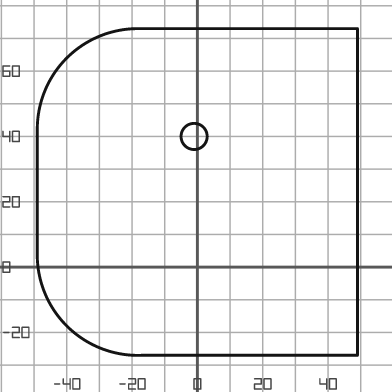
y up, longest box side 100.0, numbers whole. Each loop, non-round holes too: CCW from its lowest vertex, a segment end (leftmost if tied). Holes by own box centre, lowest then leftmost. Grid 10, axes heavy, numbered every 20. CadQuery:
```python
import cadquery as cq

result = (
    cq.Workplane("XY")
    .moveTo(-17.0, -27.0)
    .lineTo(49.0, -27.0)
    .lineTo(49.0, 73.0)
    .lineTo(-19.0, 73.0)
    .threePointArc((-40.0, 64.0), (-49.0, 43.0))
    .lineTo(-49.0, 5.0)
    .threePointArc((-40.0, -18.0), (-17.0, -27.0))
    .close()
    .moveTo(-1.0, 40.0)
    .circle(4.0)
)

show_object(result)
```